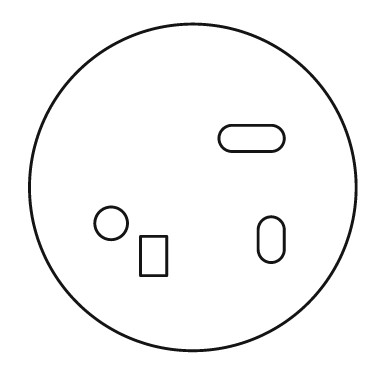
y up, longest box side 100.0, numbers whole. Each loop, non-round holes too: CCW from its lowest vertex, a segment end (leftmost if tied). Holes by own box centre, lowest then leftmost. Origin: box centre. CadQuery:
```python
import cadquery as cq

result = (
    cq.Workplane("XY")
    .moveTo(0.0, 0.0)
    .circle(50.0)
    .moveTo(-16.0, -27.0)
    .lineTo(-8.0, -27.0)
    .lineTo(-8.0, -15.0)
    .lineTo(-16.0, -15.0)
    .close()
    .moveTo(20.0, -19.0)
    .threePointArc((24.0, -23.0), (28.0, -19.0))
    .lineTo(28.0, -13.0)
    .threePointArc((24.0, -9.0), (20.0, -13.0))
    .close()
    .moveTo(-25.0, -11.0)
    .circle(5.0)
    .moveTo(12.0, 11.0)
    .lineTo(24.0, 11.0)
    .threePointArc((28.0, 15.0), (24.0, 19.0))
    .lineTo(12.0, 19.0)
    .threePointArc((8.0, 15.0), (12.0, 11.0))
    .close()
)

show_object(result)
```